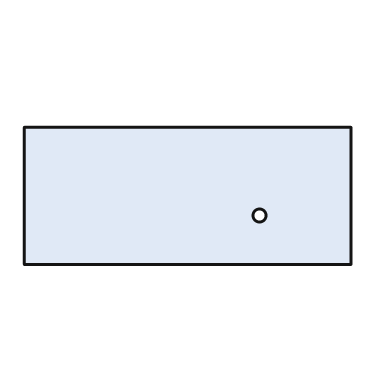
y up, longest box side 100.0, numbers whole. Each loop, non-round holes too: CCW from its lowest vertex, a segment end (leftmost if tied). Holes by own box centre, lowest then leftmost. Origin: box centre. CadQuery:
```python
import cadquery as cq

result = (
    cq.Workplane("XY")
    .moveTo(-50.0, -21.0)
    .lineTo(50.0, -21.0)
    .lineTo(50.0, 21.0)
    .lineTo(-50.0, 21.0)
    .close()
    .moveTo(22.0, -6.0)
    .circle(2.0)
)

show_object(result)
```